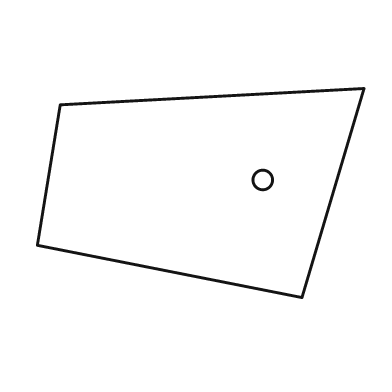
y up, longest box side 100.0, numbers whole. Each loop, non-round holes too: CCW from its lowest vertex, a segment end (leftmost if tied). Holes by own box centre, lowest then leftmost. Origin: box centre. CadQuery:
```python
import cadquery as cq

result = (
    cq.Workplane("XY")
    .moveTo(31.0, -32.0)
    .lineTo(50.0, 32.0)
    .lineTo(-43.0, 27.0)
    .lineTo(-50.0, -16.0)
    .close()
    .moveTo(19.0, 4.0)
    .circle(3.0)
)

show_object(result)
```